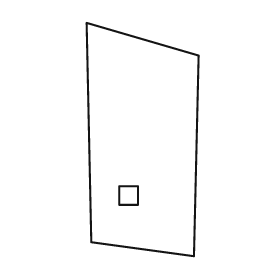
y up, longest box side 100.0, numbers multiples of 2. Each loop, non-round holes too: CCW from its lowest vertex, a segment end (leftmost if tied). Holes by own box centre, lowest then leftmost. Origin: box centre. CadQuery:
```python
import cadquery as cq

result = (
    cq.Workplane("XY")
    .moveTo(22.0, -50.0)
    .lineTo(24.0, 36.0)
    .lineTo(-24.0, 50.0)
    .lineTo(-22.0, -44.0)
    .close()
    .moveTo(-10.0, -28.0)
    .lineTo(-2.0, -28.0)
    .lineTo(-2.0, -20.0)
    .lineTo(-10.0, -20.0)
    .close()
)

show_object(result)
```